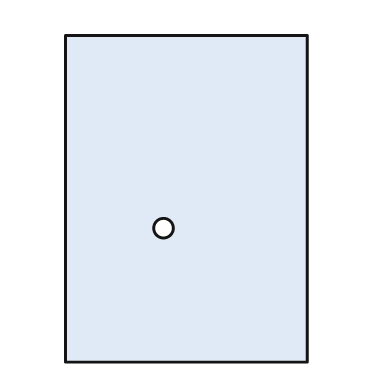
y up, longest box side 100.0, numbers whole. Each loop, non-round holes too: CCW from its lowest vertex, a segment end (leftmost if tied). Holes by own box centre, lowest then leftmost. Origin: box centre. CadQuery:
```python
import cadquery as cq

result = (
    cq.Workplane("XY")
    .moveTo(-37.0, -50.0)
    .lineTo(37.0, -50.0)
    .lineTo(37.0, 50.0)
    .lineTo(-37.0, 50.0)
    .close()
    .moveTo(-7.0, -9.0)
    .circle(3.0)
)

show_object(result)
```